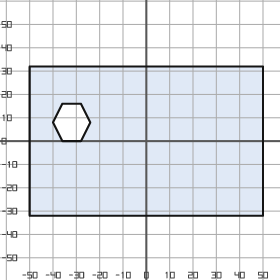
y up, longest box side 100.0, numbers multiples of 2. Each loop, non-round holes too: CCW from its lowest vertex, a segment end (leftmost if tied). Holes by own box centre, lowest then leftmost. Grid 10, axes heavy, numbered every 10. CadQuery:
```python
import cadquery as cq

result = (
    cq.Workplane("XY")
    .moveTo(-50.0, -32.0)
    .lineTo(50.0, -32.0)
    .lineTo(50.0, 32.0)
    .lineTo(-50.0, 32.0)
    .close()
    .moveTo(-36.0, 0.0)
    .lineTo(-28.0, 0.0)
    .lineTo(-24.0, 8.0)
    .lineTo(-28.0, 16.0)
    .lineTo(-36.0, 16.0)
    .lineTo(-40.0, 8.0)
    .close()
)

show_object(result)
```